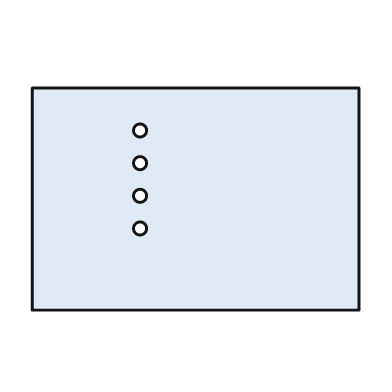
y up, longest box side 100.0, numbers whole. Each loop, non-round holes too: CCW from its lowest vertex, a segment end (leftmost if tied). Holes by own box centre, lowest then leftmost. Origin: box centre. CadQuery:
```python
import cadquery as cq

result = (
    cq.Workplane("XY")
    .moveTo(-50.0, -34.0)
    .lineTo(50.0, -34.0)
    .lineTo(50.0, 34.0)
    .lineTo(-50.0, 34.0)
    .close()
    .moveTo(-17.0, -9.0)
    .circle(2.0)
    .moveTo(-17.0, 1.0)
    .circle(2.0)
    .moveTo(-17.0, 11.0)
    .circle(2.0)
    .moveTo(-17.0, 21.0)
    .circle(2.0)
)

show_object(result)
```